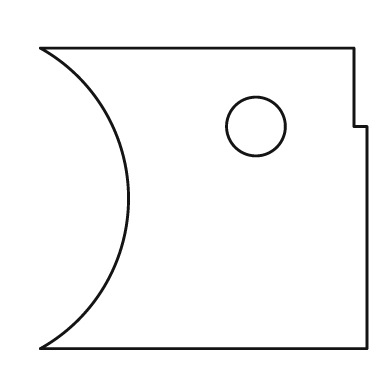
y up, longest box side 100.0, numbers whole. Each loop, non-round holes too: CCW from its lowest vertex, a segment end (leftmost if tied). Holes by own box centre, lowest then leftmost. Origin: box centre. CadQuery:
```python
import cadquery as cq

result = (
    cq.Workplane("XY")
    .moveTo(-50.0, -46.0)
    .lineTo(50.0, -46.0)
    .lineTo(50.0, 22.0)
    .lineTo(46.0, 22.0)
    .lineTo(46.0, 46.0)
    .lineTo(-50.0, 46.0)
    .threePointArc((-23.0, 0.0), (-50.0, -46.0))
    .close()
    .moveTo(16.0, 22.0)
    .circle(9.0)
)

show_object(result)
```